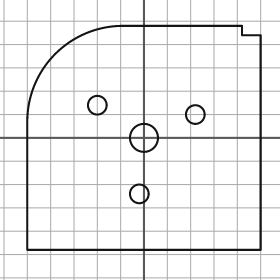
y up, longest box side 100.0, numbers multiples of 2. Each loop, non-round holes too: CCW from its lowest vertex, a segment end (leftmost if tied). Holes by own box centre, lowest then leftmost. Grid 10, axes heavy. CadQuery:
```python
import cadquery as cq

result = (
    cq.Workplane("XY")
    .moveTo(-50.0, -48.0)
    .lineTo(50.0, -48.0)
    .lineTo(50.0, 44.0)
    .lineTo(42.0, 44.0)
    .lineTo(42.0, 48.0)
    .lineTo(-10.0, 48.0)
    .threePointArc((-38.0, 36.0), (-50.0, 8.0))
    .close()
    .moveTo(-2.0, -24.0)
    .circle(4.0)
    .moveTo(0.0, 0.0)
    .circle(6.0)
    .moveTo(22.0, 10.0)
    .circle(4.0)
    .moveTo(-20.0, 14.0)
    .circle(4.0)
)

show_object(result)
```